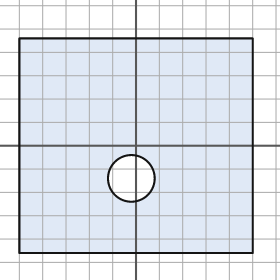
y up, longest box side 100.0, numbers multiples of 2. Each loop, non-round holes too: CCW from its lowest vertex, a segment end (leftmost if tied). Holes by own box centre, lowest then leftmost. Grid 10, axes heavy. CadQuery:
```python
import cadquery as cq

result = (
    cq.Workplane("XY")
    .moveTo(-50.0, -46.0)
    .lineTo(50.0, -46.0)
    .lineTo(50.0, 46.0)
    .lineTo(-50.0, 46.0)
    .close()
    .moveTo(-2.0, -14.0)
    .circle(10.0)
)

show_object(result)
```